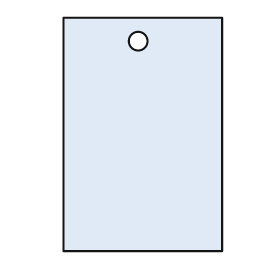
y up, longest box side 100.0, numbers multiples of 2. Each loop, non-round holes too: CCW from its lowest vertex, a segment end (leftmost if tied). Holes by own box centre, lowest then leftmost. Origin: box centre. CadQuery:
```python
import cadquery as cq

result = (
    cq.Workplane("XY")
    .moveTo(-34.0, -50.0)
    .lineTo(34.0, -50.0)
    .lineTo(34.0, 50.0)
    .lineTo(-34.0, 50.0)
    .close()
    .moveTo(-2.0, 40.0)
    .circle(4.0)
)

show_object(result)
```